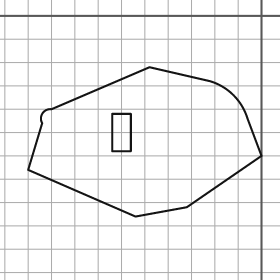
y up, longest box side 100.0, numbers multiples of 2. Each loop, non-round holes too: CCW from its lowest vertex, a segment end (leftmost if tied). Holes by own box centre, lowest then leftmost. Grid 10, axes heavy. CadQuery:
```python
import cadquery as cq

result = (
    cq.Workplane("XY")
    .moveTo(-54.0, -86.0)
    .lineTo(-32.0, -82.0)
    .lineTo(0.0, -60.0)
    .lineTo(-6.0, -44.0)
    .threePointArc((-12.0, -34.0), (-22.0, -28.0))
    .lineTo(-48.0, -22.0)
    .lineTo(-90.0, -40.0)
    .threePointArc((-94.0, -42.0), (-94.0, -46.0))
    .lineTo(-100.0, -66.0)
    .close()
    .moveTo(-64.0, -58.0)
    .lineTo(-56.0, -58.0)
    .lineTo(-56.0, -42.0)
    .lineTo(-64.0, -42.0)
    .close()
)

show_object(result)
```